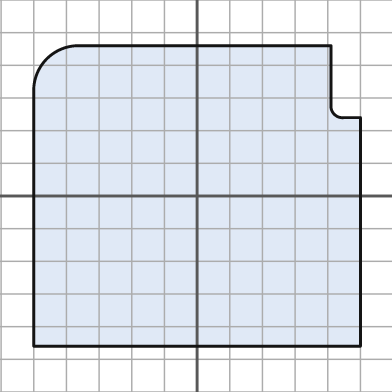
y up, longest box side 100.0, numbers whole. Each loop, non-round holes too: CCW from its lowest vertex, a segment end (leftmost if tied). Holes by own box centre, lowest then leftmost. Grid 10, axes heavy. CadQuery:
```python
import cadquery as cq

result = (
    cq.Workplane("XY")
    .moveTo(-50.0, -46.0)
    .lineTo(50.0, -46.0)
    .lineTo(50.0, 24.0)
    .lineTo(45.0, 24.0)
    .threePointArc((42.0, 25.0), (41.0, 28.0))
    .lineTo(41.0, 46.0)
    .lineTo(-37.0, 46.0)
    .threePointArc((-46.0, 42.0), (-50.0, 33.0))
    .close()
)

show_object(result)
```